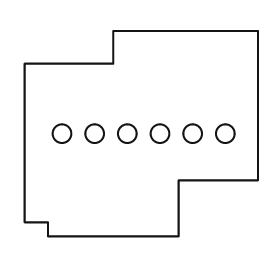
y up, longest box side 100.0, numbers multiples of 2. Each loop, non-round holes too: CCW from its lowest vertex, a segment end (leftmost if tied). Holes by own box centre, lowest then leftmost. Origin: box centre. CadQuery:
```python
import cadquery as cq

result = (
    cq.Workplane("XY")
    .moveTo(-40.0, -44.0)
    .lineTo(16.0, -44.0)
    .lineTo(16.0, -20.0)
    .lineTo(50.0, -20.0)
    .lineTo(50.0, 44.0)
    .lineTo(-12.0, 44.0)
    .lineTo(-12.0, 30.0)
    .lineTo(-50.0, 30.0)
    .lineTo(-50.0, -38.0)
    .lineTo(-40.0, -38.0)
    .close()
    .moveTo(-34.0, 0.0)
    .circle(4.0)
    .moveTo(-20.0, 0.0)
    .circle(4.0)
    .moveTo(-6.0, 0.0)
    .circle(4.0)
    .moveTo(8.0, 0.0)
    .circle(4.0)
    .moveTo(22.0, 0.0)
    .circle(4.0)
    .moveTo(36.0, 0.0)
    .circle(4.0)
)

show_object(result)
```